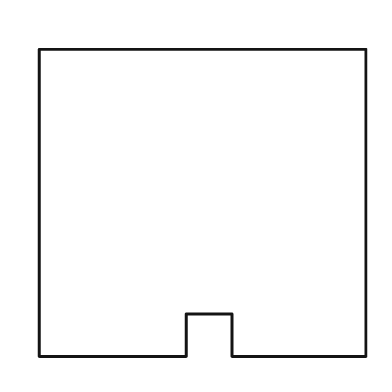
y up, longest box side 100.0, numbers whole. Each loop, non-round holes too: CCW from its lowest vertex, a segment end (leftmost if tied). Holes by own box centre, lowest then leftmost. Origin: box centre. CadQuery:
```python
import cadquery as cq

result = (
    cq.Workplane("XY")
    .moveTo(-50.0, -47.0)
    .lineTo(-5.0, -47.0)
    .lineTo(-5.0, -34.0)
    .lineTo(9.0, -34.0)
    .lineTo(9.0, -47.0)
    .lineTo(50.0, -47.0)
    .lineTo(50.0, 47.0)
    .lineTo(-50.0, 47.0)
    .close()
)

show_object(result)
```